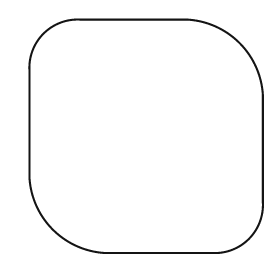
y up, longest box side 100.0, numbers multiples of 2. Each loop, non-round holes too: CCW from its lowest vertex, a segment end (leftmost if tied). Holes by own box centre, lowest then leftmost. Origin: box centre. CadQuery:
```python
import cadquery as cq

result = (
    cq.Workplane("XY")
    .moveTo(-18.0, -50.0)
    .lineTo(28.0, -50.0)
    .threePointArc((44.0, -44.0), (50.0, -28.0))
    .lineTo(50.0, 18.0)
    .threePointArc((40.0, 40.0), (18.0, 50.0))
    .lineTo(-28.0, 50.0)
    .threePointArc((-44.0, 44.0), (-50.0, 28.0))
    .lineTo(-50.0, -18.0)
    .threePointArc((-40.0, -40.0), (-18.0, -50.0))
    .close()
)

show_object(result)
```